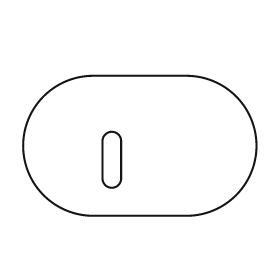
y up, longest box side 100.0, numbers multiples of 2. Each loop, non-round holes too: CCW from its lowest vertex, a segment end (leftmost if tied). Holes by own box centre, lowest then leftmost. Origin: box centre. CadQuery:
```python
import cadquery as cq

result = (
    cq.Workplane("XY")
    .moveTo(-20.0, -30.0)
    .lineTo(20.0, -30.0)
    .threePointArc((50.0, 0.0), (20.0, 30.0))
    .lineTo(-20.0, 30.0)
    .threePointArc((-50.0, 0.0), (-20.0, -30.0))
    .close()
    .moveTo(-16.0, -14.0)
    .threePointArc((-12.0, -18.0), (-8.0, -14.0))
    .lineTo(-8.0, 2.0)
    .threePointArc((-12.0, 6.0), (-16.0, 2.0))
    .close()
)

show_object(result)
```